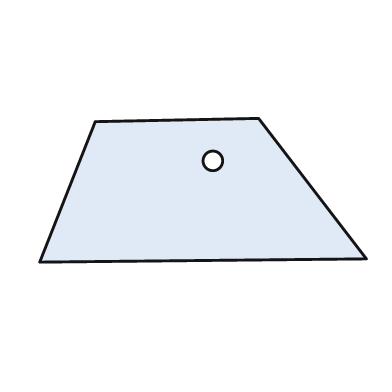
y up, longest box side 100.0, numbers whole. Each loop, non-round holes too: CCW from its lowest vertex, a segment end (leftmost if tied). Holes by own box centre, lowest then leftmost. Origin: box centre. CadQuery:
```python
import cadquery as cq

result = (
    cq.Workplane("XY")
    .moveTo(-50.0, -22.0)
    .lineTo(50.0, -21.0)
    .lineTo(17.0, 22.0)
    .lineTo(-33.0, 21.0)
    .close()
    .moveTo(3.0, 9.0)
    .circle(3.0)
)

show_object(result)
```